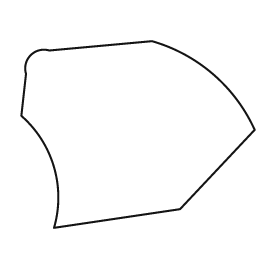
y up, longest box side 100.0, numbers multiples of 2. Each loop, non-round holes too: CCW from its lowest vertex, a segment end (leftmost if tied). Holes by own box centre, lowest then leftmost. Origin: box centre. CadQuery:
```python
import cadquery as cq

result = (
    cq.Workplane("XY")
    .moveTo(-36.0, -40.0)
    .lineTo(18.0, -32.0)
    .lineTo(50.0, 2.0)
    .threePointArc((32.0, 26.0), (6.0, 40.0))
    .lineTo(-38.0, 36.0)
    .threePointArc((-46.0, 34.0), (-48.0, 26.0))
    .lineTo(-50.0, 8.0)
    .threePointArc((-36.0, -14.0), (-36.0, -40.0))
    .close()
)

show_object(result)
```